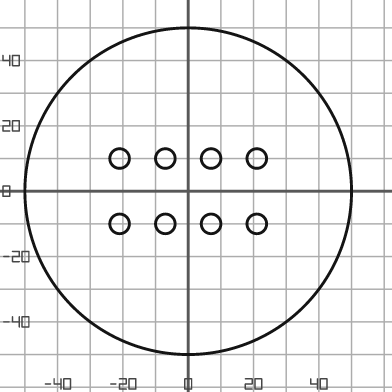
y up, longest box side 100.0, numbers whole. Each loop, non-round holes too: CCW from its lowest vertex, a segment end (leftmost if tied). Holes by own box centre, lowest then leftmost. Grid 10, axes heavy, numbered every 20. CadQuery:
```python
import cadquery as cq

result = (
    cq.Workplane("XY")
    .moveTo(0.0, 0.0)
    .circle(50.0)
    .moveTo(-21.0, -10.0)
    .circle(3.0)
    .moveTo(-7.0, -10.0)
    .circle(3.0)
    .moveTo(7.0, -10.0)
    .circle(3.0)
    .moveTo(21.0, -10.0)
    .circle(3.0)
    .moveTo(-21.0, 10.0)
    .circle(3.0)
    .moveTo(-7.0, 10.0)
    .circle(3.0)
    .moveTo(7.0, 10.0)
    .circle(3.0)
    .moveTo(21.0, 10.0)
    .circle(3.0)
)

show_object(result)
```